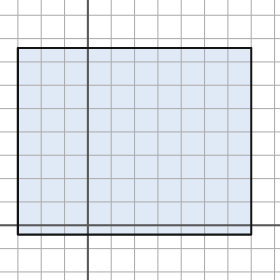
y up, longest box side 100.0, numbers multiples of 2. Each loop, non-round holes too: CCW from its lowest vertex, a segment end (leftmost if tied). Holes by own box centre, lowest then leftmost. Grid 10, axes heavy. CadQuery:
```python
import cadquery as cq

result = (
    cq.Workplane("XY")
    .moveTo(-30.0, -4.0)
    .lineTo(70.0, -4.0)
    .lineTo(70.0, 76.0)
    .lineTo(-30.0, 76.0)
    .close()
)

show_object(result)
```